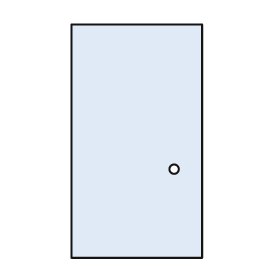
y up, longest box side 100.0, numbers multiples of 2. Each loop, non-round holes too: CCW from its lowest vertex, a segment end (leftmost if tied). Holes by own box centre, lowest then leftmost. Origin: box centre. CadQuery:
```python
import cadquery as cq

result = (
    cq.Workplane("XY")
    .moveTo(-28.0, -50.0)
    .lineTo(28.0, -50.0)
    .lineTo(28.0, 50.0)
    .lineTo(-28.0, 50.0)
    .close()
    .moveTo(16.0, -12.0)
    .circle(2.0)
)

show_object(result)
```